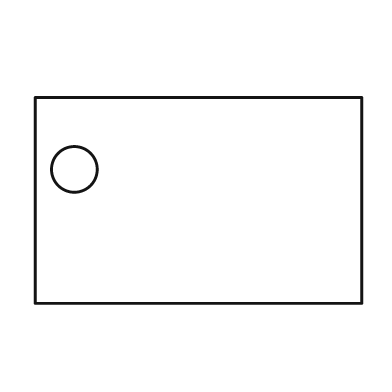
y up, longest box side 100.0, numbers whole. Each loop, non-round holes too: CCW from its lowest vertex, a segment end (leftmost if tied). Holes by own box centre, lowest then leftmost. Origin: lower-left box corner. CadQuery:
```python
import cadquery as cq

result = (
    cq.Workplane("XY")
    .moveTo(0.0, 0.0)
    .lineTo(100.0, 0.0)
    .lineTo(100.0, 63.0)
    .lineTo(0.0, 63.0)
    .close()
    .moveTo(12.0, 41.0)
    .circle(7.0)
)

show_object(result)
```